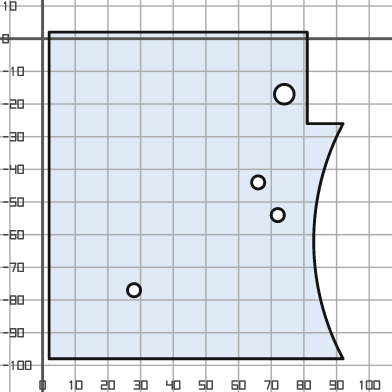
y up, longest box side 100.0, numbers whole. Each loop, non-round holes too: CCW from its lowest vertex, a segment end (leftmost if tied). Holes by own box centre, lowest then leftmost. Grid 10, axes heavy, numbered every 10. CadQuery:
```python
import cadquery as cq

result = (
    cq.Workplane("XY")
    .moveTo(2.0, -98.0)
    .lineTo(92.0, -98.0)
    .threePointArc((83.0, -62.0), (92.0, -26.0))
    .lineTo(81.0, -26.0)
    .lineTo(81.0, 2.0)
    .lineTo(2.0, 2.0)
    .close()
    .moveTo(28.0, -77.0)
    .circle(2.0)
    .moveTo(72.0, -54.0)
    .circle(2.0)
    .moveTo(66.0, -44.0)
    .circle(2.0)
    .moveTo(74.0, -17.0)
    .circle(3.0)
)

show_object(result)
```